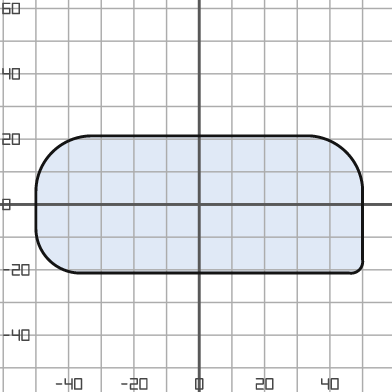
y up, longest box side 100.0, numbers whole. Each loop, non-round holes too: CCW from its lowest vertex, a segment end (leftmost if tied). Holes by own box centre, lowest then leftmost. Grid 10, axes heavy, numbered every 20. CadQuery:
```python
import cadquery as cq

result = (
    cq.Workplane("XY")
    .moveTo(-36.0, -21.0)
    .lineTo(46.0, -21.0)
    .threePointArc((49.0, -20.0), (50.0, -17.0))
    .lineTo(50.0, 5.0)
    .threePointArc((45.0, 16.0), (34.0, 21.0))
    .lineTo(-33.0, 21.0)
    .threePointArc((-45.0, 16.0), (-50.0, 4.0))
    .lineTo(-50.0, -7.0)
    .threePointArc((-46.0, -17.0), (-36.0, -21.0))
    .close()
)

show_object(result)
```